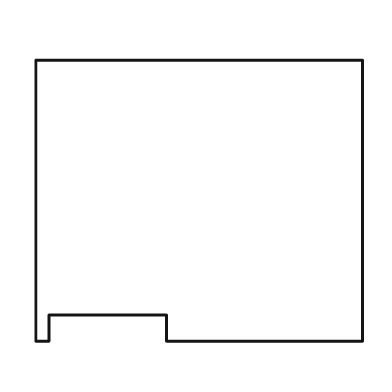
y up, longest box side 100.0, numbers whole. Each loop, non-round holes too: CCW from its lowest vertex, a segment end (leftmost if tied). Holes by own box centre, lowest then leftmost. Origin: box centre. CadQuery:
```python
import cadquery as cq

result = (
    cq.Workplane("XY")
    .moveTo(-50.0, -43.0)
    .lineTo(-46.0, -43.0)
    .lineTo(-46.0, -35.0)
    .lineTo(-10.0, -35.0)
    .lineTo(-10.0, -43.0)
    .lineTo(50.0, -43.0)
    .lineTo(50.0, 43.0)
    .lineTo(-50.0, 43.0)
    .close()
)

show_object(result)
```